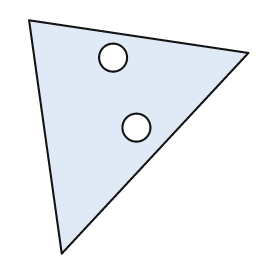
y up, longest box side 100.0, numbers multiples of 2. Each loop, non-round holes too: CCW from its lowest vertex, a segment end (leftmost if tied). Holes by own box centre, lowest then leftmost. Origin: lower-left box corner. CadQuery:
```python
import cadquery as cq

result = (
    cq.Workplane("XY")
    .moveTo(14.0, 0.0)
    .lineTo(94.0, 86.0)
    .lineTo(0.0, 100.0)
    .close()
    .moveTo(46.0, 54.0)
    .circle(6.0)
    .moveTo(36.0, 84.0)
    .circle(6.0)
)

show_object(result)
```